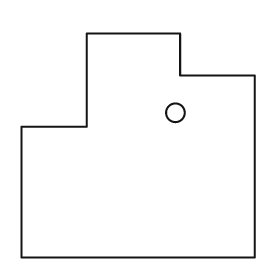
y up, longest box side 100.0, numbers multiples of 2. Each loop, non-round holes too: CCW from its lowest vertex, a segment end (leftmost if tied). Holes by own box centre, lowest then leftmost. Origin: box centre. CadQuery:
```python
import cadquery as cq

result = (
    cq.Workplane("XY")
    .moveTo(-50.0, -48.0)
    .lineTo(50.0, -48.0)
    .lineTo(50.0, 30.0)
    .lineTo(18.0, 30.0)
    .lineTo(18.0, 48.0)
    .lineTo(-22.0, 48.0)
    .lineTo(-22.0, 8.0)
    .lineTo(-50.0, 8.0)
    .close()
    .moveTo(16.0, 14.0)
    .circle(4.0)
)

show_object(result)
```